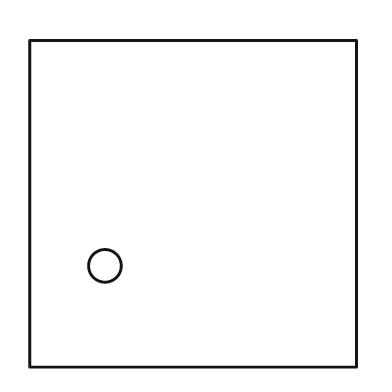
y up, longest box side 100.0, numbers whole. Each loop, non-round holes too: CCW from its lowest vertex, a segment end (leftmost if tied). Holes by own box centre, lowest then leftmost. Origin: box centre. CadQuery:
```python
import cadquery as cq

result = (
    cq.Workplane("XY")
    .moveTo(-50.0, -50.0)
    .lineTo(50.0, -50.0)
    .lineTo(50.0, 50.0)
    .lineTo(-50.0, 50.0)
    .close()
    .moveTo(-27.0, -19.0)
    .circle(5.0)
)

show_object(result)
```